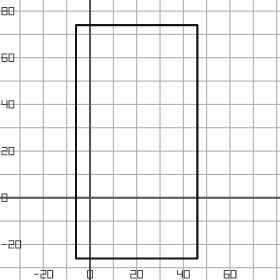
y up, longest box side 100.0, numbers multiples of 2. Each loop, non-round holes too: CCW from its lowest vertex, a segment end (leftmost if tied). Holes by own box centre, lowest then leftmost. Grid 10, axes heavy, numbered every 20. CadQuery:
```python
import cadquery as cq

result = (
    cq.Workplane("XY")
    .moveTo(-6.0, -26.0)
    .lineTo(46.0, -26.0)
    .lineTo(46.0, 74.0)
    .lineTo(-6.0, 74.0)
    .close()
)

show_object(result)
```